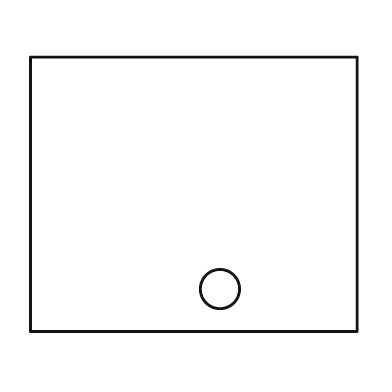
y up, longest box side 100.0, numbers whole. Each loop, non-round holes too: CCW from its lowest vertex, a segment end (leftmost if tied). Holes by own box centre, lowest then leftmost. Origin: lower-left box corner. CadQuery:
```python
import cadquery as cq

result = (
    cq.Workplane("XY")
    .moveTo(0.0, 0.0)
    .lineTo(100.0, 0.0)
    .lineTo(100.0, 84.0)
    .lineTo(0.0, 84.0)
    .close()
    .moveTo(58.0, 13.0)
    .circle(6.0)
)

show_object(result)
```